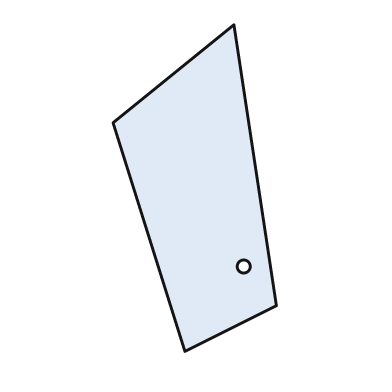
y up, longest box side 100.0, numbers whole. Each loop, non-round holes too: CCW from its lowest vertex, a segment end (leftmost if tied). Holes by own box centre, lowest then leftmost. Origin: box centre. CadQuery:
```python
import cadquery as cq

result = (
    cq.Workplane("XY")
    .moveTo(-3.0, -50.0)
    .lineTo(25.0, -36.0)
    .lineTo(12.0, 50.0)
    .lineTo(-25.0, 20.0)
    .close()
    .moveTo(15.0, -24.0)
    .circle(2.0)
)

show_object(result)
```